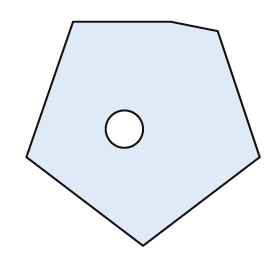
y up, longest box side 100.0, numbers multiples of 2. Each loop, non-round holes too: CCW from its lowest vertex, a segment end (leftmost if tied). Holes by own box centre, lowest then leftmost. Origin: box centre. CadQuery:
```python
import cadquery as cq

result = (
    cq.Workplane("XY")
    .moveTo(0.0, -48.0)
    .lineTo(50.0, -10.0)
    .lineTo(32.0, 44.0)
    .lineTo(12.0, 48.0)
    .lineTo(-30.0, 48.0)
    .lineTo(-50.0, -10.0)
    .close()
    .moveTo(-8.0, 2.0)
    .circle(8.0)
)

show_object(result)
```